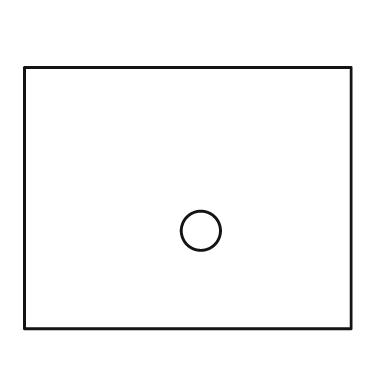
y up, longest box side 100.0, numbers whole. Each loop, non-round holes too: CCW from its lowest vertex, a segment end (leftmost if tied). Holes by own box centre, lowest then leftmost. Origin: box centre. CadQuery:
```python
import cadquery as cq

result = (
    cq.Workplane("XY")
    .moveTo(-50.0, -40.0)
    .lineTo(50.0, -40.0)
    .lineTo(50.0, 40.0)
    .lineTo(-50.0, 40.0)
    .close()
    .moveTo(4.0, -10.0)
    .circle(6.0)
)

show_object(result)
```